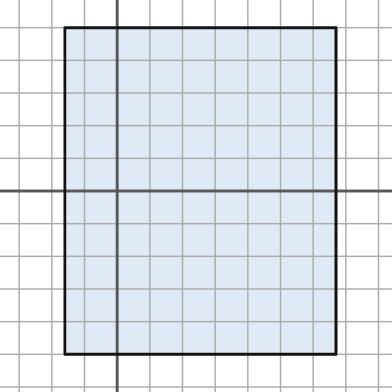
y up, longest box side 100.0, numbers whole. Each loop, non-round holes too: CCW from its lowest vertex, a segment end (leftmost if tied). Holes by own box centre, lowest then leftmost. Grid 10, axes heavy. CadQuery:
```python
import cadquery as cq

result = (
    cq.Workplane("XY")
    .moveTo(-16.0, -50.0)
    .lineTo(67.0, -50.0)
    .lineTo(67.0, 50.0)
    .lineTo(-16.0, 50.0)
    .close()
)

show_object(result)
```